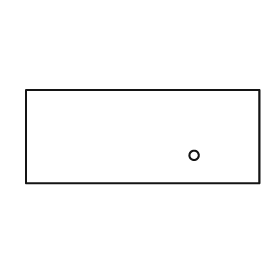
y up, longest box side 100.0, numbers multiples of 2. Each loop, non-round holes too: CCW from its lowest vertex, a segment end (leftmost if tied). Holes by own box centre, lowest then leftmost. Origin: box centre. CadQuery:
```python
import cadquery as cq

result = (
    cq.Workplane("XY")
    .moveTo(-50.0, -20.0)
    .lineTo(50.0, -20.0)
    .lineTo(50.0, 20.0)
    .lineTo(-50.0, 20.0)
    .close()
    .moveTo(22.0, -8.0)
    .circle(2.0)
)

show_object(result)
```